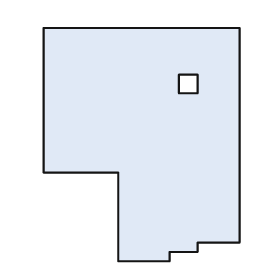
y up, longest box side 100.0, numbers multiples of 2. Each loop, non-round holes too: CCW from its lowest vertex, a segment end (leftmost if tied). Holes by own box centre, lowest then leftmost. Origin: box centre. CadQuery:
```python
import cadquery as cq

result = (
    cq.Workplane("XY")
    .moveTo(-10.0, -50.0)
    .lineTo(12.0, -50.0)
    .lineTo(12.0, -46.0)
    .lineTo(24.0, -46.0)
    .lineTo(24.0, -42.0)
    .lineTo(42.0, -42.0)
    .lineTo(42.0, 50.0)
    .lineTo(-42.0, 50.0)
    .lineTo(-42.0, -12.0)
    .lineTo(-10.0, -12.0)
    .close()
    .moveTo(16.0, 22.0)
    .lineTo(24.0, 22.0)
    .lineTo(24.0, 30.0)
    .lineTo(16.0, 30.0)
    .close()
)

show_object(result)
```